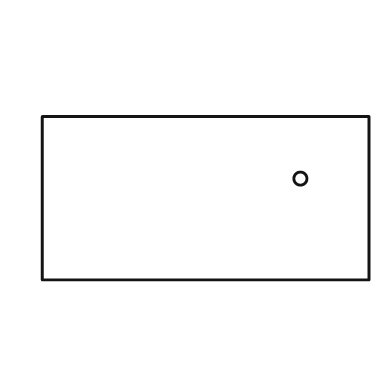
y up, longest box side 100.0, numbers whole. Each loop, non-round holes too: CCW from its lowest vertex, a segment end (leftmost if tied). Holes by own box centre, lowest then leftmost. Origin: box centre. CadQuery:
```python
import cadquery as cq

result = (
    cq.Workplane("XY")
    .moveTo(-50.0, -25.0)
    .lineTo(50.0, -25.0)
    .lineTo(50.0, 25.0)
    .lineTo(-50.0, 25.0)
    .close()
    .moveTo(29.0, 6.0)
    .circle(2.0)
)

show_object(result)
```